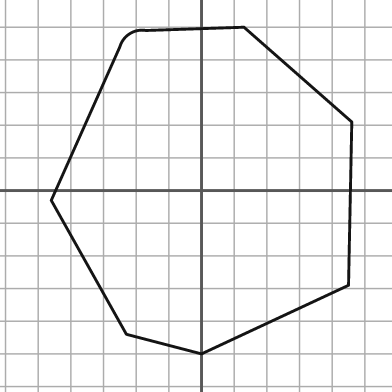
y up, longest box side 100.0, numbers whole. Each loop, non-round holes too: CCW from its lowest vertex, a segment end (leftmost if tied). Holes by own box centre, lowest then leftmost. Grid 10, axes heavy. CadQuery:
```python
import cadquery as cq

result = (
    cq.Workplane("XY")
    .moveTo(0.0, -50.0)
    .lineTo(45.0, -29.0)
    .lineTo(46.0, 21.0)
    .lineTo(13.0, 50.0)
    .lineTo(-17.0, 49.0)
    .threePointArc((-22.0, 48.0), (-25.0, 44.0))
    .lineTo(-46.0, -3.0)
    .lineTo(-23.0, -44.0)
    .close()
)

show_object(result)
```